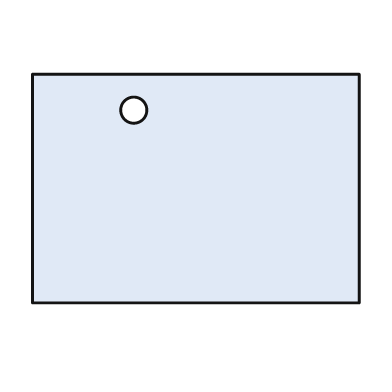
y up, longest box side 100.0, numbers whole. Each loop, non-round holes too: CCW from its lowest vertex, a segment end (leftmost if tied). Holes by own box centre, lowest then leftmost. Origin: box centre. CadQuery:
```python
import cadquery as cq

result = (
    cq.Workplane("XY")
    .moveTo(-50.0, -35.0)
    .lineTo(50.0, -35.0)
    .lineTo(50.0, 35.0)
    .lineTo(-50.0, 35.0)
    .close()
    .moveTo(-19.0, 24.0)
    .circle(4.0)
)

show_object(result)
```